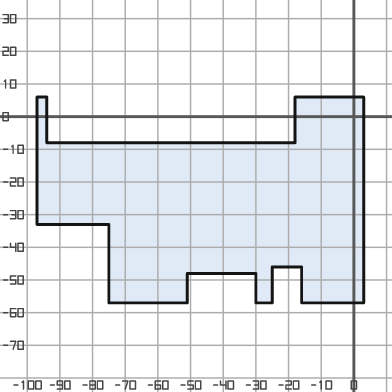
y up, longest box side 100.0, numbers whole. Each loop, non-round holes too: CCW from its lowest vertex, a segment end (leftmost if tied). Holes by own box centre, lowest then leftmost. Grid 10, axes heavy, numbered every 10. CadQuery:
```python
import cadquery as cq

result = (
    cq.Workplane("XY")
    .moveTo(-75.0, -57.0)
    .lineTo(-51.0, -57.0)
    .lineTo(-51.0, -48.0)
    .lineTo(-30.0, -48.0)
    .lineTo(-30.0, -57.0)
    .lineTo(-25.0, -57.0)
    .lineTo(-25.0, -46.0)
    .lineTo(-16.0, -46.0)
    .lineTo(-16.0, -57.0)
    .lineTo(3.0, -57.0)
    .lineTo(3.0, 6.0)
    .lineTo(-18.0, 6.0)
    .lineTo(-18.0, -8.0)
    .lineTo(-94.0, -8.0)
    .lineTo(-94.0, 6.0)
    .lineTo(-97.0, 6.0)
    .lineTo(-97.0, -33.0)
    .lineTo(-75.0, -33.0)
    .close()
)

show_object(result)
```